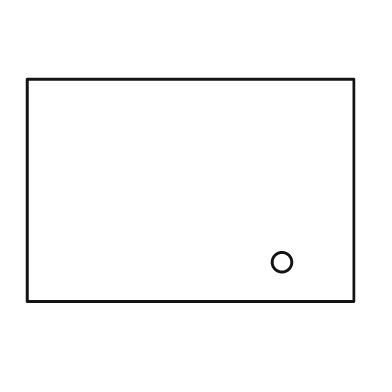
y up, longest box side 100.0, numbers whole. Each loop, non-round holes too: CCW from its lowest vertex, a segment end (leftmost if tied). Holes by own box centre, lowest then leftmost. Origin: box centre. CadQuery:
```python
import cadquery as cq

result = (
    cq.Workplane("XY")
    .moveTo(-50.0, -34.0)
    .lineTo(50.0, -34.0)
    .lineTo(50.0, 34.0)
    .lineTo(-50.0, 34.0)
    .close()
    .moveTo(28.0, -22.0)
    .circle(3.0)
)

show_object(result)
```